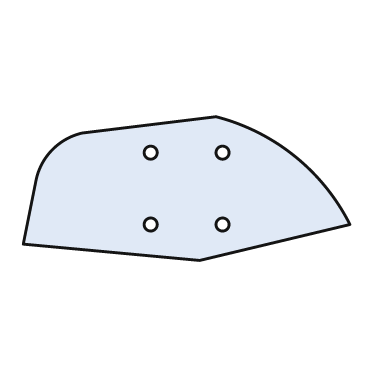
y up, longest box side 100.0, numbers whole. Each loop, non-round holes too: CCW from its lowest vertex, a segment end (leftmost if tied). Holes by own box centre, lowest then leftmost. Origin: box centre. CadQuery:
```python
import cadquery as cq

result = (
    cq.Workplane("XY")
    .moveTo(4.0, -22.0)
    .lineTo(50.0, -11.0)
    .threePointArc((33.0, 10.0), (9.0, 22.0))
    .lineTo(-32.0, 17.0)
    .threePointArc((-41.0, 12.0), (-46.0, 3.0))
    .lineTo(-50.0, -17.0)
    .close()
    .moveTo(-11.0, -11.0)
    .circle(2.0)
    .moveTo(11.0, -11.0)
    .circle(2.0)
    .moveTo(-11.0, 11.0)
    .circle(2.0)
    .moveTo(11.0, 11.0)
    .circle(2.0)
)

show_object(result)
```